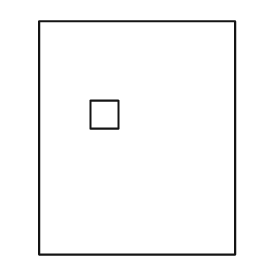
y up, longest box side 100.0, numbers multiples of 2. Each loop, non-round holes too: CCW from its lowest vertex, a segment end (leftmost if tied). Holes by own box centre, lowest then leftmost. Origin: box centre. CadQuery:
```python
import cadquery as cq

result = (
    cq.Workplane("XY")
    .moveTo(-42.0, -50.0)
    .lineTo(42.0, -50.0)
    .lineTo(42.0, 50.0)
    .lineTo(-42.0, 50.0)
    .close()
    .moveTo(-20.0, 4.0)
    .lineTo(-8.0, 4.0)
    .lineTo(-8.0, 16.0)
    .lineTo(-20.0, 16.0)
    .close()
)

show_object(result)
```